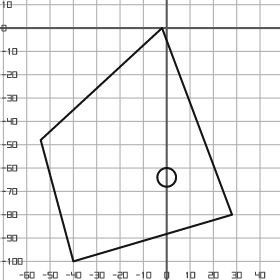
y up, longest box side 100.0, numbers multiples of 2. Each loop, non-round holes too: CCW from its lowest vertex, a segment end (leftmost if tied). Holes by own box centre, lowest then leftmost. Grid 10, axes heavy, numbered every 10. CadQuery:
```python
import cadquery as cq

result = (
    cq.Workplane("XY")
    .moveTo(-40.0, -100.0)
    .lineTo(28.0, -80.0)
    .lineTo(-2.0, 0.0)
    .lineTo(-54.0, -48.0)
    .close()
    .moveTo(0.0, -64.0)
    .circle(4.0)
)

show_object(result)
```